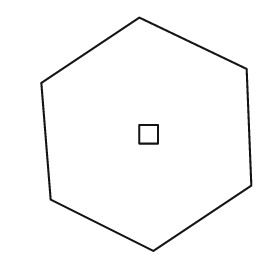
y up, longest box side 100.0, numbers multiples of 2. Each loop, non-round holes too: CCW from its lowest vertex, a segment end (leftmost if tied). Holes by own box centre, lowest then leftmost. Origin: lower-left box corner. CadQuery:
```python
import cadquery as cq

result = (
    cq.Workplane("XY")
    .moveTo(48.0, 0.0)
    .lineTo(90.0, 28.0)
    .lineTo(88.0, 78.0)
    .lineTo(42.0, 100.0)
    .lineTo(0.0, 72.0)
    .lineTo(4.0, 22.0)
    .close()
    .moveTo(42.0, 46.0)
    .lineTo(50.0, 46.0)
    .lineTo(50.0, 54.0)
    .lineTo(42.0, 54.0)
    .close()
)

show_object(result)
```